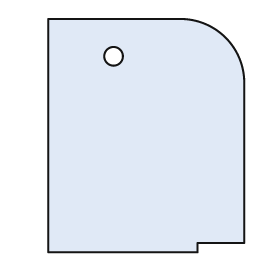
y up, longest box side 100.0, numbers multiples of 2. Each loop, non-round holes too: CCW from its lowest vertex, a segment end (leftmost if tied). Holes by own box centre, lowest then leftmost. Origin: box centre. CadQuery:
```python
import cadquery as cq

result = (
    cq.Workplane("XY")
    .moveTo(-42.0, -50.0)
    .lineTo(22.0, -50.0)
    .lineTo(22.0, -46.0)
    .lineTo(42.0, -46.0)
    .lineTo(42.0, 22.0)
    .threePointArc((34.0, 42.0), (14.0, 50.0))
    .lineTo(-42.0, 50.0)
    .close()
    .moveTo(-14.0, 34.0)
    .circle(4.0)
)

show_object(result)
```